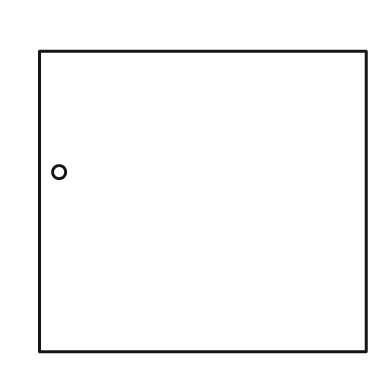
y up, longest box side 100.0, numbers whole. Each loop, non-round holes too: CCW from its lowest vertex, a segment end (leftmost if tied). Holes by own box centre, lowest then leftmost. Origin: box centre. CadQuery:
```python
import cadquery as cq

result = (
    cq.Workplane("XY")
    .moveTo(-50.0, -46.0)
    .lineTo(50.0, -46.0)
    .lineTo(50.0, 46.0)
    .lineTo(-50.0, 46.0)
    .close()
    .moveTo(-44.0, 9.0)
    .circle(2.0)
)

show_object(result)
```